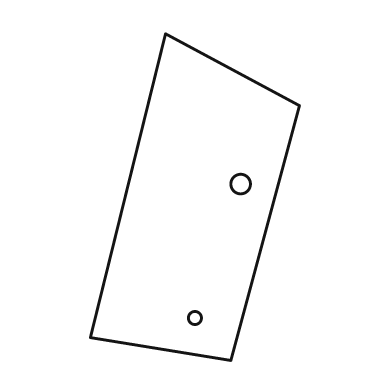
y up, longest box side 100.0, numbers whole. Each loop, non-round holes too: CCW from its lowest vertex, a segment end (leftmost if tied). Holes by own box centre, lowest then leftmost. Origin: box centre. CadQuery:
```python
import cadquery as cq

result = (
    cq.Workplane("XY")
    .moveTo(11.0, -50.0)
    .lineTo(32.0, 28.0)
    .lineTo(-9.0, 50.0)
    .lineTo(-32.0, -43.0)
    .close()
    .moveTo(0.0, -37.0)
    .circle(2.0)
    .moveTo(14.0, 4.0)
    .circle(3.0)
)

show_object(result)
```